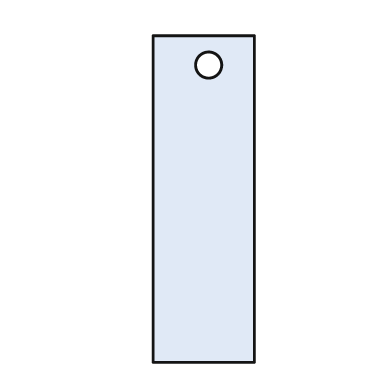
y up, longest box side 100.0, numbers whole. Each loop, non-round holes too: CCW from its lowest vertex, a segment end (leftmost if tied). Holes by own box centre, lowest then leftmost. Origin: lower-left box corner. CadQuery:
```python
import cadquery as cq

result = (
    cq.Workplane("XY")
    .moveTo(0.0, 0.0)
    .lineTo(31.0, 0.0)
    .lineTo(31.0, 100.0)
    .lineTo(0.0, 100.0)
    .close()
    .moveTo(17.0, 91.0)
    .circle(4.0)
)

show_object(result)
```